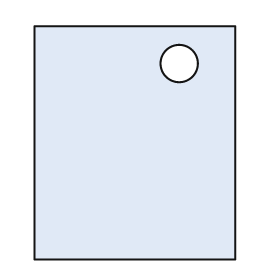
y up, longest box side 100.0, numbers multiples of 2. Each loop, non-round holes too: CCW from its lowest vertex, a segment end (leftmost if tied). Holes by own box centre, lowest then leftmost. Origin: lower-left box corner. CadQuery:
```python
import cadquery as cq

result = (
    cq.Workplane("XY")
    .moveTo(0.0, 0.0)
    .lineTo(86.0, 0.0)
    .lineTo(86.0, 100.0)
    .lineTo(0.0, 100.0)
    .close()
    .moveTo(62.0, 84.0)
    .circle(8.0)
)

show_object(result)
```